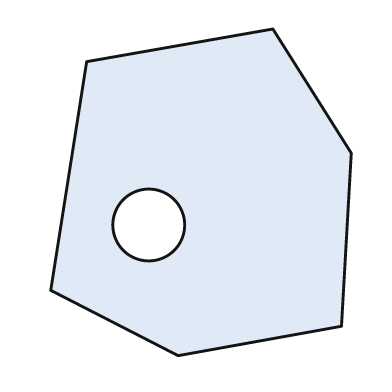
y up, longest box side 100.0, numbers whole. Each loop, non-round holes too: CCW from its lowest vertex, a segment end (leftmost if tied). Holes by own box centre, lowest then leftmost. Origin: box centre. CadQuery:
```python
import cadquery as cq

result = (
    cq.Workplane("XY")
    .moveTo(-7.0, -50.0)
    .lineTo(43.0, -41.0)
    .lineTo(46.0, 12.0)
    .lineTo(22.0, 50.0)
    .lineTo(-35.0, 40.0)
    .lineTo(-46.0, -30.0)
    .close()
    .moveTo(-16.0, -10.0)
    .circle(11.0)
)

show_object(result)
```